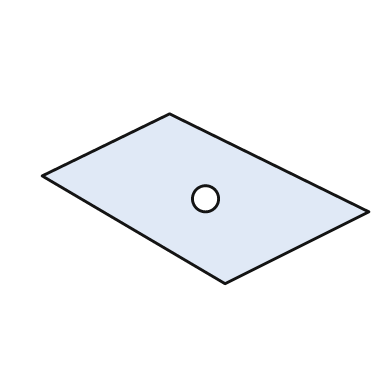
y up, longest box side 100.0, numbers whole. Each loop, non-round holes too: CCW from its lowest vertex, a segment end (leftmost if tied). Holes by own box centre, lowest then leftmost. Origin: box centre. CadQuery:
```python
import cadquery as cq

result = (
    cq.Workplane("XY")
    .moveTo(6.0, -26.0)
    .lineTo(50.0, -4.0)
    .lineTo(-11.0, 26.0)
    .lineTo(-50.0, 7.0)
    .close()
    .moveTo(0.0, 0.0)
    .circle(4.0)
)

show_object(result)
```